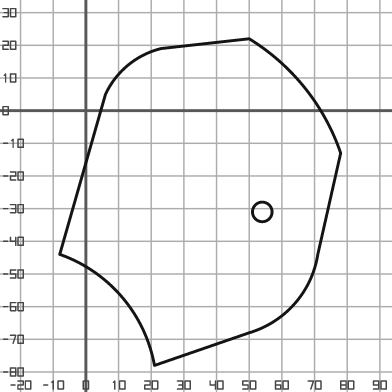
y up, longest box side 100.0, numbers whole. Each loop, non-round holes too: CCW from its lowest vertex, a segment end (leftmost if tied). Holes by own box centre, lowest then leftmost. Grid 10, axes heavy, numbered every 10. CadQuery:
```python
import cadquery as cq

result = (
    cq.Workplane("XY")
    .moveTo(21.0, -78.0)
    .lineTo(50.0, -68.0)
    .threePointArc((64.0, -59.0), (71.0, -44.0))
    .lineTo(78.0, -13.0)
    .threePointArc((67.0, 7.0), (50.0, 22.0))
    .lineTo(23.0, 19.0)
    .threePointArc((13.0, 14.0), (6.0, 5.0))
    .lineTo(-8.0, -44.0)
    .threePointArc((11.0, -57.0), (21.0, -78.0))
    .close()
    .moveTo(54.0, -31.0)
    .circle(3.0)
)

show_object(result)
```